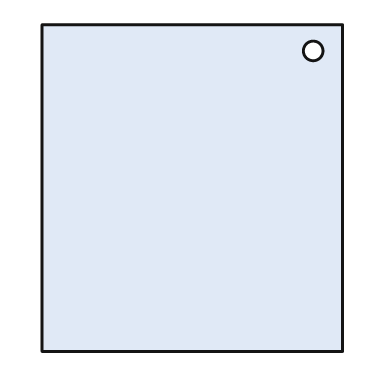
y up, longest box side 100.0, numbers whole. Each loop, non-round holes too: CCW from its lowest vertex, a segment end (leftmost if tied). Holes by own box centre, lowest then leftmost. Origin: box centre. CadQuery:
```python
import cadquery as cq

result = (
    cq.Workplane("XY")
    .moveTo(-46.0, -50.0)
    .lineTo(46.0, -50.0)
    .lineTo(46.0, 50.0)
    .lineTo(-46.0, 50.0)
    .close()
    .moveTo(37.0, 42.0)
    .circle(3.0)
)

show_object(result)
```